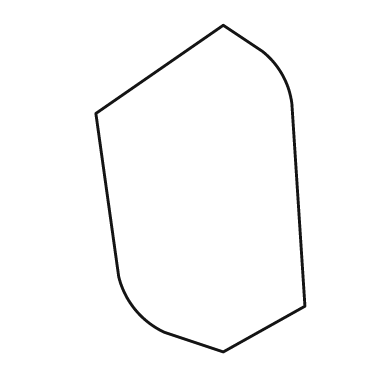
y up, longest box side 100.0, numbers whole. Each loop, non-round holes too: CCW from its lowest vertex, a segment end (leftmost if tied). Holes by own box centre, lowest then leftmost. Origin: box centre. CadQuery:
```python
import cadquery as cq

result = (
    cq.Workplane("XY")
    .moveTo(7.0, -50.0)
    .lineTo(32.0, -36.0)
    .lineTo(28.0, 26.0)
    .threePointArc((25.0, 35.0), (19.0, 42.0))
    .lineTo(7.0, 50.0)
    .lineTo(-32.0, 23.0)
    .lineTo(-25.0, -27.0)
    .threePointArc((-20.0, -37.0), (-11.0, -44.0))
    .close()
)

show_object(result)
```